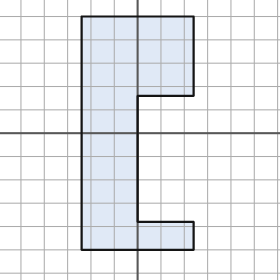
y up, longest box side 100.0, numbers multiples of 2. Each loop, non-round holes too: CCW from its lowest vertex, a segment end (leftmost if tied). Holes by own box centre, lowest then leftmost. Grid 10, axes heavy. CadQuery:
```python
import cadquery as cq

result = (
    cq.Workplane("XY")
    .moveTo(-24.0, -50.0)
    .lineTo(24.0, -50.0)
    .lineTo(24.0, -38.0)
    .lineTo(0.0, -38.0)
    .lineTo(0.0, 16.0)
    .lineTo(24.0, 16.0)
    .lineTo(24.0, 50.0)
    .lineTo(-24.0, 50.0)
    .close()
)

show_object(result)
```